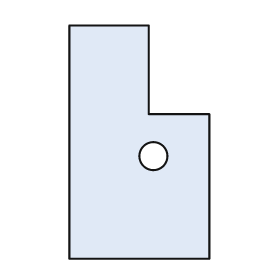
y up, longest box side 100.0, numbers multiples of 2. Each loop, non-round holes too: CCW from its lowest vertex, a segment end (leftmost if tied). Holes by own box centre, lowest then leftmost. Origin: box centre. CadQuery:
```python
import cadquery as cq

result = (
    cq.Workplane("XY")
    .moveTo(-30.0, -50.0)
    .lineTo(30.0, -50.0)
    .lineTo(30.0, 12.0)
    .lineTo(4.0, 12.0)
    .lineTo(4.0, 50.0)
    .lineTo(-30.0, 50.0)
    .close()
    .moveTo(6.0, -6.0)
    .circle(6.0)
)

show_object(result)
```